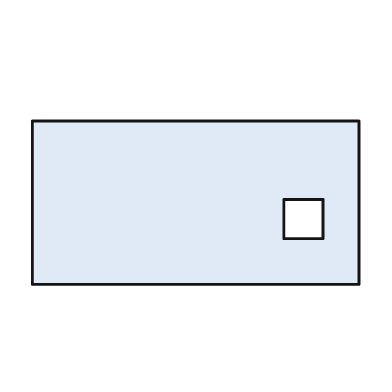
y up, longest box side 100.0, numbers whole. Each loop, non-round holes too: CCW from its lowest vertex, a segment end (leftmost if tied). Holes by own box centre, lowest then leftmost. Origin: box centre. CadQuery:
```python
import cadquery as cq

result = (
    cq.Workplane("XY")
    .moveTo(-50.0, -25.0)
    .lineTo(50.0, -25.0)
    .lineTo(50.0, 25.0)
    .lineTo(-50.0, 25.0)
    .close()
    .moveTo(27.0, -11.0)
    .lineTo(39.0, -11.0)
    .lineTo(39.0, 1.0)
    .lineTo(27.0, 1.0)
    .close()
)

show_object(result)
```